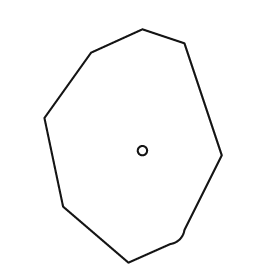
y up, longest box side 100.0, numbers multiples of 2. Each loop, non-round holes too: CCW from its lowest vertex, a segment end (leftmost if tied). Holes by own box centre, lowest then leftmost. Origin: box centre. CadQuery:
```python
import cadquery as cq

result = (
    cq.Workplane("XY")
    .moveTo(-2.0, -50.0)
    .lineTo(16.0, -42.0)
    .threePointArc((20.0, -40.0), (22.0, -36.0))
    .lineTo(38.0, -4.0)
    .lineTo(22.0, 44.0)
    .lineTo(4.0, 50.0)
    .lineTo(-18.0, 40.0)
    .lineTo(-38.0, 12.0)
    .lineTo(-30.0, -26.0)
    .close()
    .moveTo(4.0, -2.0)
    .circle(2.0)
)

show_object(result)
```